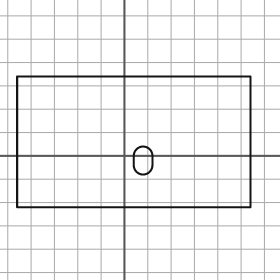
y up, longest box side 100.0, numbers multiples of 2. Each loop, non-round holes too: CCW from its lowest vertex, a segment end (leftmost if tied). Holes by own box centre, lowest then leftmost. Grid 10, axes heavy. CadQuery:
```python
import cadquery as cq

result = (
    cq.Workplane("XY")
    .moveTo(-46.0, -22.0)
    .lineTo(54.0, -22.0)
    .lineTo(54.0, 34.0)
    .lineTo(-46.0, 34.0)
    .close()
    .moveTo(4.0, -4.0)
    .threePointArc((8.0, -8.0), (12.0, -4.0))
    .lineTo(12.0, 0.0)
    .threePointArc((8.0, 4.0), (4.0, 0.0))
    .close()
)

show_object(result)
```